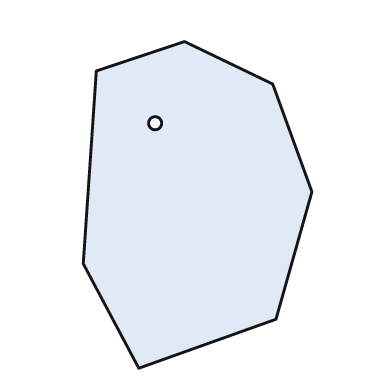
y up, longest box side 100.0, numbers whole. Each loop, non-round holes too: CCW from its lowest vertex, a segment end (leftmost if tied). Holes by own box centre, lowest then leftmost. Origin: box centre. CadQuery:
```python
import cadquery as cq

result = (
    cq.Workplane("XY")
    .moveTo(-18.0, -50.0)
    .lineTo(24.0, -35.0)
    .lineTo(35.0, 4.0)
    .lineTo(23.0, 37.0)
    .lineTo(-4.0, 50.0)
    .lineTo(-31.0, 41.0)
    .lineTo(-35.0, -18.0)
    .close()
    .moveTo(-13.0, 25.0)
    .circle(2.0)
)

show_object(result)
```